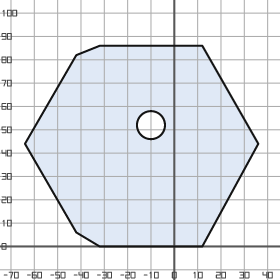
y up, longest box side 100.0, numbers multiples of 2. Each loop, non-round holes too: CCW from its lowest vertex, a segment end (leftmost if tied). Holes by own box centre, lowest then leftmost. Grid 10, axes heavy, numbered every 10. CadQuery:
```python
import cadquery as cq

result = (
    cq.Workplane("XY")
    .moveTo(-32.0, 0.0)
    .lineTo(12.0, 0.0)
    .lineTo(36.0, 44.0)
    .lineTo(12.0, 86.0)
    .lineTo(-32.0, 86.0)
    .lineTo(-42.0, 82.0)
    .lineTo(-64.0, 44.0)
    .lineTo(-42.0, 6.0)
    .close()
    .moveTo(-10.0, 52.0)
    .circle(6.0)
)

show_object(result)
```